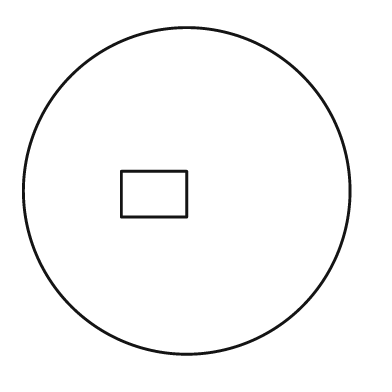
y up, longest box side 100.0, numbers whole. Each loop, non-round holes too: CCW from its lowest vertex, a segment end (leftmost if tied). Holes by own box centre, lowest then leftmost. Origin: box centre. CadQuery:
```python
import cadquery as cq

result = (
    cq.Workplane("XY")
    .moveTo(0.0, 0.0)
    .circle(50.0)
    .moveTo(-20.0, -8.0)
    .lineTo(0.0, -8.0)
    .lineTo(0.0, 6.0)
    .lineTo(-20.0, 6.0)
    .close()
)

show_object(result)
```